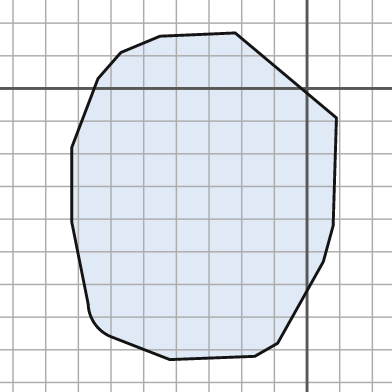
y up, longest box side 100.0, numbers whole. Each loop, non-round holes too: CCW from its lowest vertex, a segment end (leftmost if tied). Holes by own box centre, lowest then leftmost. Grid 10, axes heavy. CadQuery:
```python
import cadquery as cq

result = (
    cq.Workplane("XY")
    .moveTo(-42.0, -83.0)
    .lineTo(-16.0, -82.0)
    .lineTo(-9.0, -78.0)
    .lineTo(5.0, -53.0)
    .lineTo(8.0, -42.0)
    .lineTo(9.0, -9.0)
    .lineTo(-22.0, 17.0)
    .lineTo(-45.0, 16.0)
    .lineTo(-57.0, 11.0)
    .lineTo(-64.0, 3.0)
    .lineTo(-72.0, -18.0)
    .lineTo(-72.0, -41.0)
    .lineTo(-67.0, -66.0)
    .threePointArc((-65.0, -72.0), (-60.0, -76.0))
    .close()
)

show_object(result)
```